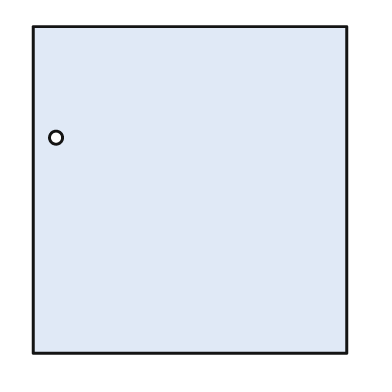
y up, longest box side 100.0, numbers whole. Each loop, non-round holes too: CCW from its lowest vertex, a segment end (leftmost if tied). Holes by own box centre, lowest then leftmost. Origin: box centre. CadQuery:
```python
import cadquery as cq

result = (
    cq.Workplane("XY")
    .moveTo(-48.0, -50.0)
    .lineTo(48.0, -50.0)
    .lineTo(48.0, 50.0)
    .lineTo(-48.0, 50.0)
    .close()
    .moveTo(-41.0, 16.0)
    .circle(2.0)
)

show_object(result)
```